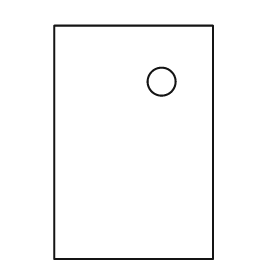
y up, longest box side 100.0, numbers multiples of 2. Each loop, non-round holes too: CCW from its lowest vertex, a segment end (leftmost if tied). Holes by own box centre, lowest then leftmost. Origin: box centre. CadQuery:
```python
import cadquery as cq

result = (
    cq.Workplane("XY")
    .moveTo(-34.0, -50.0)
    .lineTo(34.0, -50.0)
    .lineTo(34.0, 50.0)
    .lineTo(-34.0, 50.0)
    .close()
    .moveTo(12.0, 26.0)
    .circle(6.0)
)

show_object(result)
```